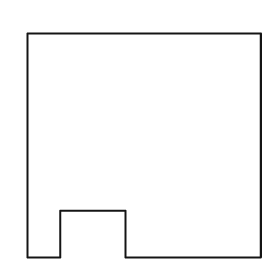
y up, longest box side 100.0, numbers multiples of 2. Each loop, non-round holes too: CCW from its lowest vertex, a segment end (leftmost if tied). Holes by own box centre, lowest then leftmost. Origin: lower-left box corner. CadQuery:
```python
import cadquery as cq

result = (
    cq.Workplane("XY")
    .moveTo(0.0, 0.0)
    .lineTo(14.0, 0.0)
    .lineTo(14.0, 20.0)
    .lineTo(42.0, 20.0)
    .lineTo(42.0, 0.0)
    .lineTo(100.0, 0.0)
    .lineTo(100.0, 96.0)
    .lineTo(0.0, 96.0)
    .close()
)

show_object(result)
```